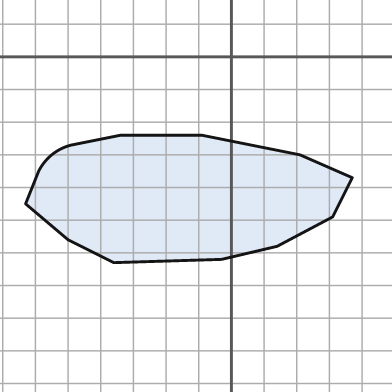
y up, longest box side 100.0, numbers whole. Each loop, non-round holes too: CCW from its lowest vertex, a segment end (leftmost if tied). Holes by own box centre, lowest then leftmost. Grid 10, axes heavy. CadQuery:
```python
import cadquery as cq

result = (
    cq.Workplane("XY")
    .moveTo(-36.0, -63.0)
    .lineTo(-3.0, -62.0)
    .lineTo(14.0, -58.0)
    .lineTo(31.0, -49.0)
    .lineTo(37.0, -37.0)
    .lineTo(21.0, -30.0)
    .lineTo(-9.0, -24.0)
    .lineTo(-34.0, -24.0)
    .lineTo(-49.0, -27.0)
    .threePointArc((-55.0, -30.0), (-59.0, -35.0))
    .lineTo(-63.0, -45.0)
    .lineTo(-50.0, -56.0)
    .close()
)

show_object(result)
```